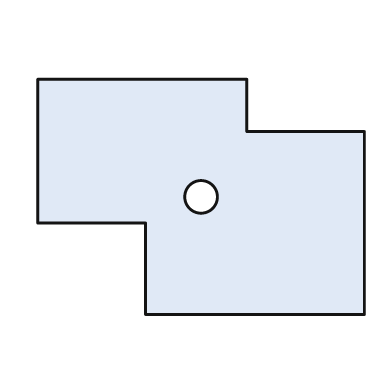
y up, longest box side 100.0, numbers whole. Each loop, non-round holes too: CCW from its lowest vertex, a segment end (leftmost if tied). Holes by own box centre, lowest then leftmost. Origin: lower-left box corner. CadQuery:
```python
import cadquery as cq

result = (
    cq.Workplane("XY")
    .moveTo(33.0, 0.0)
    .lineTo(100.0, 0.0)
    .lineTo(100.0, 56.0)
    .lineTo(64.0, 56.0)
    .lineTo(64.0, 72.0)
    .lineTo(0.0, 72.0)
    .lineTo(0.0, 28.0)
    .lineTo(33.0, 28.0)
    .close()
    .moveTo(50.0, 36.0)
    .circle(5.0)
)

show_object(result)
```